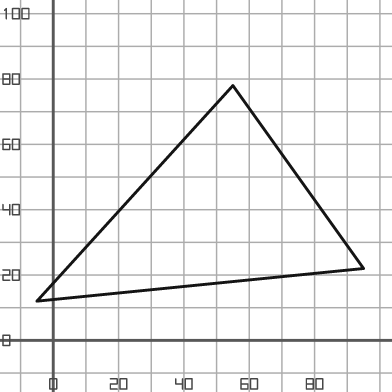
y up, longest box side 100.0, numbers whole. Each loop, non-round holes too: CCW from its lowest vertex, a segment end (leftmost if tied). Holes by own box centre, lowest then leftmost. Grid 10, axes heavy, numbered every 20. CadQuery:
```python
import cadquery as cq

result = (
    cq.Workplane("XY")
    .moveTo(-5.0, 12.0)
    .lineTo(95.0, 22.0)
    .lineTo(55.0, 78.0)
    .close()
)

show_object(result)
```